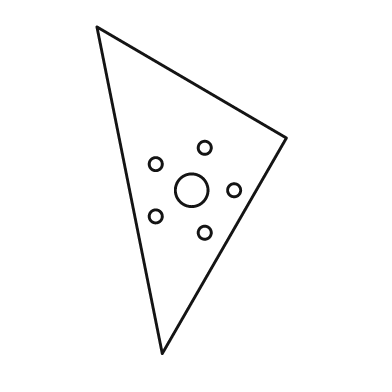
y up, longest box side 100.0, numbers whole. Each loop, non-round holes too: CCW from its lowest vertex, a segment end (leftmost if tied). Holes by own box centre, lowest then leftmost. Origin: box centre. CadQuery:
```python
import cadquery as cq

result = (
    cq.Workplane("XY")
    .moveTo(-9.0, -50.0)
    .lineTo(29.0, 16.0)
    .lineTo(-29.0, 50.0)
    .close()
    .moveTo(4.0, -13.0)
    .circle(2.0)
    .moveTo(-11.0, -8.0)
    .circle(2.0)
    .moveTo(0.0, 0.0)
    .circle(5.0)
    .moveTo(13.0, 0.0)
    .circle(2.0)
    .moveTo(-11.0, 8.0)
    .circle(2.0)
    .moveTo(4.0, 13.0)
    .circle(2.0)
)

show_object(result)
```